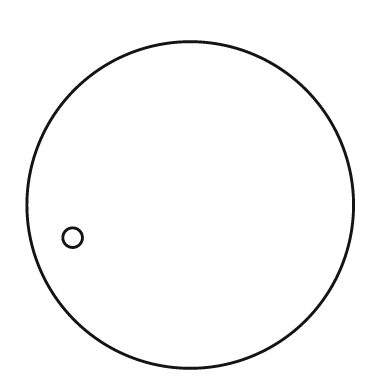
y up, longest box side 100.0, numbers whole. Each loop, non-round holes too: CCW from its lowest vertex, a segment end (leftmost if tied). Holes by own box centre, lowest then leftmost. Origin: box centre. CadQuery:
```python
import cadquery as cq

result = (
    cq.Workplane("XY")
    .moveTo(0.0, 0.0)
    .circle(50.0)
    .moveTo(-36.0, -10.0)
    .circle(3.0)
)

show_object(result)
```